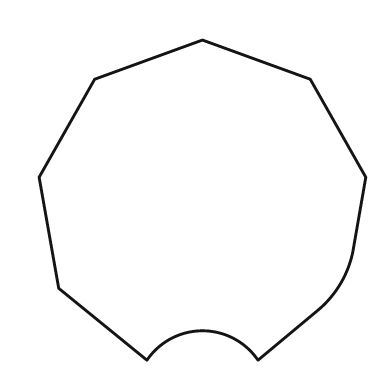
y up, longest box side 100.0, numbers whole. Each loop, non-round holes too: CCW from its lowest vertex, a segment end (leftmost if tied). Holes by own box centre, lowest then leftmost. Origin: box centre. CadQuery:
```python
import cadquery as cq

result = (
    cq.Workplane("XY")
    .moveTo(-17.0, -49.0)
    .threePointArc((0.0, -40.0), (17.0, -49.0))
    .lineTo(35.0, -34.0)
    .threePointArc((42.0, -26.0), (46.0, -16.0))
    .lineTo(50.0, 7.0)
    .lineTo(33.0, 37.0)
    .lineTo(0.0, 49.0)
    .lineTo(-33.0, 37.0)
    .lineTo(-50.0, 7.0)
    .lineTo(-44.0, -27.0)
    .close()
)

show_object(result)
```